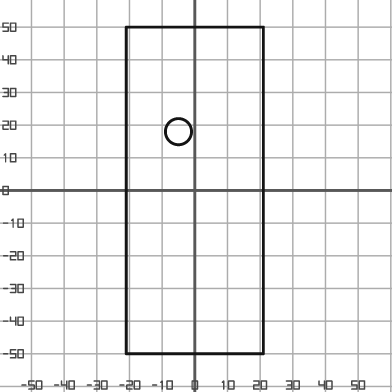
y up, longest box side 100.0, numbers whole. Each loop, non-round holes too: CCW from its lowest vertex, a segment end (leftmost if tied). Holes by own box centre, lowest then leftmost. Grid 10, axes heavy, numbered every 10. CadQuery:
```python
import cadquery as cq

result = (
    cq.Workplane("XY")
    .moveTo(-21.0, -50.0)
    .lineTo(21.0, -50.0)
    .lineTo(21.0, 50.0)
    .lineTo(-21.0, 50.0)
    .close()
    .moveTo(-5.0, 18.0)
    .circle(4.0)
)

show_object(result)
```